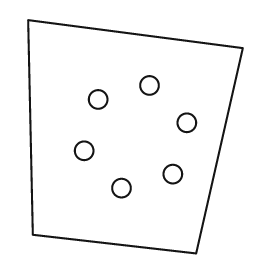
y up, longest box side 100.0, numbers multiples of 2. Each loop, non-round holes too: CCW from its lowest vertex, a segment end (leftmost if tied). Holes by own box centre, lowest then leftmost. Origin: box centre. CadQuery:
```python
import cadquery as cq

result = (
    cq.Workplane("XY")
    .moveTo(26.0, -50.0)
    .lineTo(46.0, 38.0)
    .lineTo(-46.0, 50.0)
    .lineTo(-44.0, -42.0)
    .close()
    .moveTo(-6.0, -22.0)
    .circle(4.0)
    .moveTo(16.0, -16.0)
    .circle(4.0)
    .moveTo(-22.0, -6.0)
    .circle(4.0)
    .moveTo(22.0, 6.0)
    .circle(4.0)
    .moveTo(-16.0, 16.0)
    .circle(4.0)
    .moveTo(6.0, 22.0)
    .circle(4.0)
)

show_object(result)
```